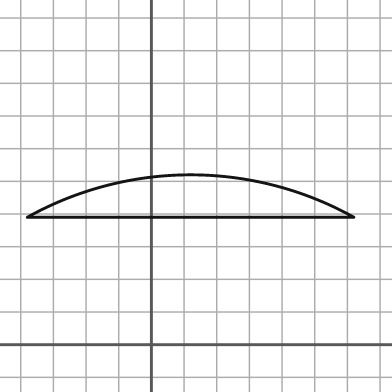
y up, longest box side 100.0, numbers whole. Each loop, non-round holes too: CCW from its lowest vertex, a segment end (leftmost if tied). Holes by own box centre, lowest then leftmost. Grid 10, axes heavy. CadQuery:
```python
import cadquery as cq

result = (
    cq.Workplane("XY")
    .moveTo(-38.0, 39.0)
    .lineTo(62.0, 39.0)
    .threePointArc((12.0, 52.0), (-38.0, 39.0))
    .close()
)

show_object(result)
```